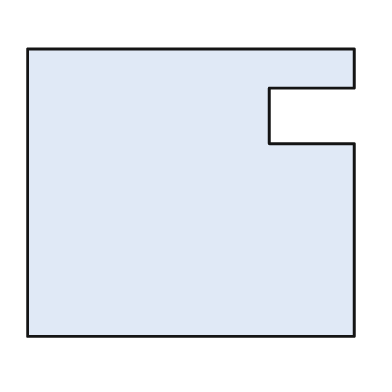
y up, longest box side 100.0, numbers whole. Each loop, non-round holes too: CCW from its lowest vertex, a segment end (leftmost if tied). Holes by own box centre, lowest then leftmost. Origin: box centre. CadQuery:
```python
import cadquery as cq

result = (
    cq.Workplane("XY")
    .moveTo(-50.0, -44.0)
    .lineTo(50.0, -44.0)
    .lineTo(50.0, 15.0)
    .lineTo(24.0, 15.0)
    .lineTo(24.0, 32.0)
    .lineTo(50.0, 32.0)
    .lineTo(50.0, 44.0)
    .lineTo(-50.0, 44.0)
    .close()
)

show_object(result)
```